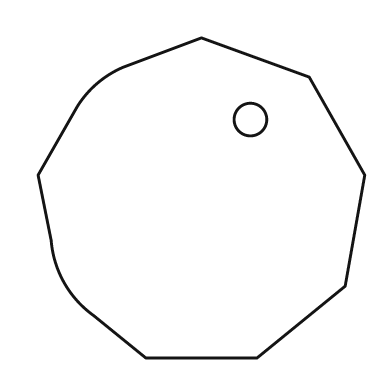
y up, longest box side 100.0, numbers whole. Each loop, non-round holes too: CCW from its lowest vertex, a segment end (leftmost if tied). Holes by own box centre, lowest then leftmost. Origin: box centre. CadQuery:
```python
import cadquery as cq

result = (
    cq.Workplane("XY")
    .moveTo(-17.0, -49.0)
    .lineTo(17.0, -49.0)
    .lineTo(44.0, -27.0)
    .lineTo(50.0, 7.0)
    .lineTo(33.0, 37.0)
    .lineTo(0.0, 49.0)
    .lineTo(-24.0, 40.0)
    .threePointArc((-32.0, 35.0), (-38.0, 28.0))
    .lineTo(-50.0, 7.0)
    .lineTo(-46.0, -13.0)
    .threePointArc((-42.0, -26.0), (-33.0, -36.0))
    .close()
    .moveTo(15.0, 24.0)
    .circle(5.0)
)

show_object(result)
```